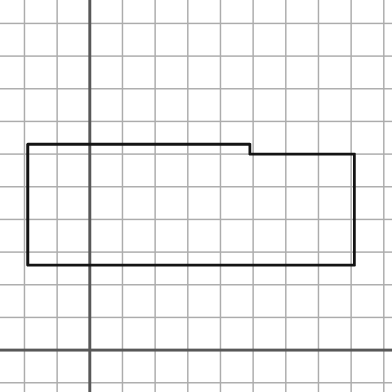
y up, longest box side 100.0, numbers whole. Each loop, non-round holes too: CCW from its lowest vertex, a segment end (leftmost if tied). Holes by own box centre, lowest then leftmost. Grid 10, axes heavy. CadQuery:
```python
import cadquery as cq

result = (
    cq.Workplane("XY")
    .moveTo(-19.0, 26.0)
    .lineTo(81.0, 26.0)
    .lineTo(81.0, 60.0)
    .lineTo(49.0, 60.0)
    .lineTo(49.0, 63.0)
    .lineTo(-19.0, 63.0)
    .close()
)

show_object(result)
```